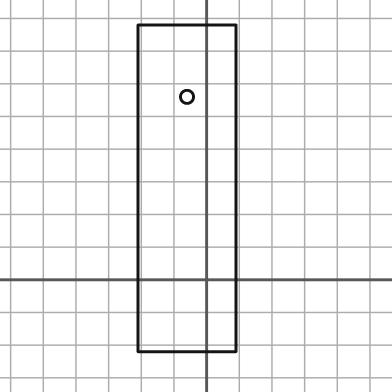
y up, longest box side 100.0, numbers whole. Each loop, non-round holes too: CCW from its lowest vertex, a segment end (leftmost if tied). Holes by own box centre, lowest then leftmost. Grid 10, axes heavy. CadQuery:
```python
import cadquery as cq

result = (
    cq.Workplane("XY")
    .moveTo(-21.0, -22.0)
    .lineTo(9.0, -22.0)
    .lineTo(9.0, 78.0)
    .lineTo(-21.0, 78.0)
    .close()
    .moveTo(-6.0, 56.0)
    .circle(2.0)
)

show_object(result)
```